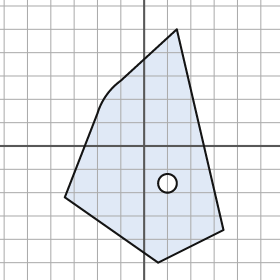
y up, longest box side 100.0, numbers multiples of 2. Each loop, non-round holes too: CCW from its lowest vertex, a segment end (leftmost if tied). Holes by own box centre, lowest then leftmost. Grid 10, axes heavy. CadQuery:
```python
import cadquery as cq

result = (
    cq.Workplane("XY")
    .moveTo(6.0, -50.0)
    .lineTo(34.0, -36.0)
    .lineTo(14.0, 50.0)
    .lineTo(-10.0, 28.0)
    .threePointArc((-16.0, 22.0), (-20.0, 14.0))
    .lineTo(-34.0, -22.0)
    .close()
    .moveTo(10.0, -16.0)
    .circle(4.0)
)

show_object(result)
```